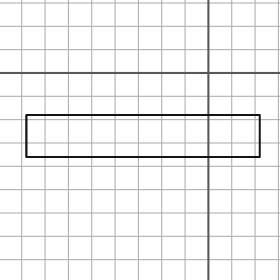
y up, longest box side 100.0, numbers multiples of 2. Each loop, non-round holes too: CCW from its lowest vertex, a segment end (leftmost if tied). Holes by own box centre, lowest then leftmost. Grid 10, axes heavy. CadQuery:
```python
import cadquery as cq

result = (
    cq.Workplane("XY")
    .moveTo(-78.0, -36.0)
    .lineTo(22.0, -36.0)
    .lineTo(22.0, -18.0)
    .lineTo(-78.0, -18.0)
    .close()
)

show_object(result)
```